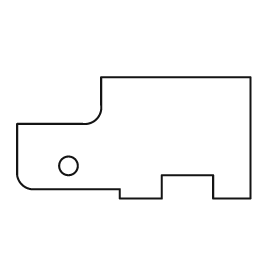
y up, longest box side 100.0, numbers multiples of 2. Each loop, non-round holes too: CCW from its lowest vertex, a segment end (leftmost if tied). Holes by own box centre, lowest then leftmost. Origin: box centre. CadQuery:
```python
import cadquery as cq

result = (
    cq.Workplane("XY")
    .moveTo(-6.0, -26.0)
    .lineTo(12.0, -26.0)
    .lineTo(12.0, -16.0)
    .lineTo(34.0, -16.0)
    .lineTo(34.0, -26.0)
    .lineTo(50.0, -26.0)
    .lineTo(50.0, 26.0)
    .lineTo(-14.0, 26.0)
    .lineTo(-14.0, 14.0)
    .threePointArc((-16.0, 8.0), (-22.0, 6.0))
    .lineTo(-50.0, 6.0)
    .lineTo(-50.0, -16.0)
    .threePointArc((-48.0, -20.0), (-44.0, -22.0))
    .lineTo(-6.0, -22.0)
    .close()
    .moveTo(-28.0, -12.0)
    .circle(4.0)
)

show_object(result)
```